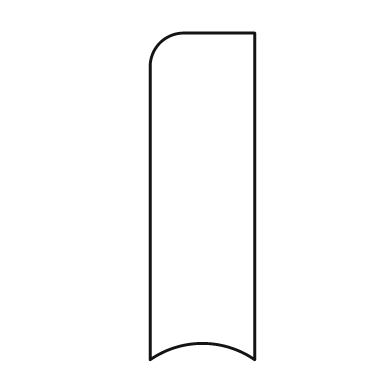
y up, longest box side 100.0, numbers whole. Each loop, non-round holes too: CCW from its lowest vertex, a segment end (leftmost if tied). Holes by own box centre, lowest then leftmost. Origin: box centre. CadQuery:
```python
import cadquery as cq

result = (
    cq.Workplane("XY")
    .moveTo(-16.0, -50.0)
    .threePointArc((0.0, -45.0), (16.0, -50.0))
    .lineTo(16.0, 50.0)
    .lineTo(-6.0, 50.0)
    .threePointArc((-13.0, 47.0), (-16.0, 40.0))
    .close()
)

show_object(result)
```